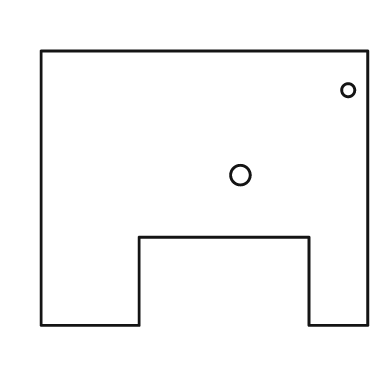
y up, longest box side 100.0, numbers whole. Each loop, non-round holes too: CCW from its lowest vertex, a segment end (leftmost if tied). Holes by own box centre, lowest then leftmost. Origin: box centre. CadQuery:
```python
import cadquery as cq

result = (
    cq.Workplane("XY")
    .moveTo(-50.0, -42.0)
    .lineTo(-20.0, -42.0)
    .lineTo(-20.0, -15.0)
    .lineTo(32.0, -15.0)
    .lineTo(32.0, -42.0)
    .lineTo(50.0, -42.0)
    .lineTo(50.0, 42.0)
    .lineTo(-50.0, 42.0)
    .close()
    .moveTo(11.0, 4.0)
    .circle(3.0)
    .moveTo(44.0, 30.0)
    .circle(2.0)
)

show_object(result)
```